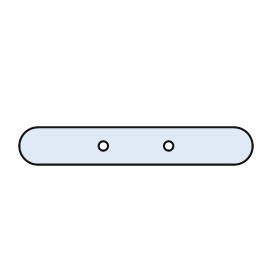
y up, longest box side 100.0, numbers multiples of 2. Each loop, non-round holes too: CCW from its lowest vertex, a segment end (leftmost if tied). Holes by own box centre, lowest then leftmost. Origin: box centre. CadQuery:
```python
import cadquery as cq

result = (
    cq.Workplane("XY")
    .moveTo(-42.0, -8.0)
    .lineTo(42.0, -8.0)
    .threePointArc((50.0, 0.0), (42.0, 8.0))
    .lineTo(-42.0, 8.0)
    .threePointArc((-50.0, 0.0), (-42.0, -8.0))
    .close()
    .moveTo(-14.0, 0.0)
    .circle(2.0)
    .moveTo(14.0, 0.0)
    .circle(2.0)
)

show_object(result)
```